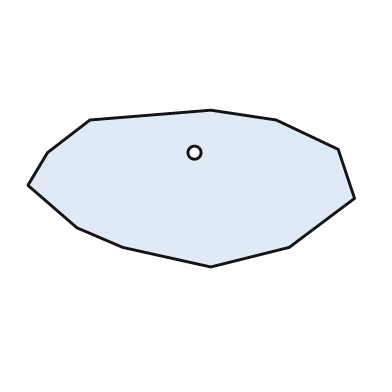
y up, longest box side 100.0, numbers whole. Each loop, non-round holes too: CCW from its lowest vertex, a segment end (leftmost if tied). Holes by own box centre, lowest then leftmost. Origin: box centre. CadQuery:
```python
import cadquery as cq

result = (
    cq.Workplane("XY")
    .moveTo(6.0, -24.0)
    .lineTo(30.0, -18.0)
    .lineTo(50.0, -3.0)
    .lineTo(45.0, 12.0)
    .lineTo(26.0, 21.0)
    .lineTo(6.0, 24.0)
    .lineTo(-31.0, 21.0)
    .lineTo(-44.0, 11.0)
    .lineTo(-50.0, 1.0)
    .lineTo(-35.0, -12.0)
    .lineTo(-21.0, -18.0)
    .close()
    .moveTo(1.0, 11.0)
    .circle(2.0)
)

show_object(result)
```